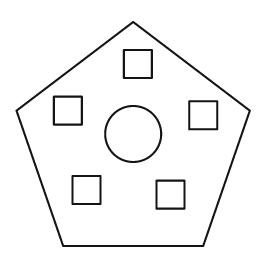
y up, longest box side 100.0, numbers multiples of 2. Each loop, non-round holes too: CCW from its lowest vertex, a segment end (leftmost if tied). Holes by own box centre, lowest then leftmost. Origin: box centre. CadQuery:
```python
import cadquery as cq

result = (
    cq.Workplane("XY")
    .moveTo(-30.0, -48.0)
    .lineTo(30.0, -48.0)
    .lineTo(50.0, 10.0)
    .lineTo(0.0, 48.0)
    .lineTo(-50.0, 10.0)
    .close()
    .moveTo(10.0, -32.0)
    .lineTo(22.0, -32.0)
    .lineTo(22.0, -20.0)
    .lineTo(10.0, -20.0)
    .close()
    .moveTo(-26.0, -30.0)
    .lineTo(-14.0, -30.0)
    .lineTo(-14.0, -18.0)
    .lineTo(-26.0, -18.0)
    .close()
    .moveTo(0.0, 0.0)
    .circle(12.0)
    .moveTo(24.0, 2.0)
    .lineTo(36.0, 2.0)
    .lineTo(36.0, 14.0)
    .lineTo(24.0, 14.0)
    .close()
    .moveTo(-34.0, 4.0)
    .lineTo(-22.0, 4.0)
    .lineTo(-22.0, 16.0)
    .lineTo(-34.0, 16.0)
    .close()
    .moveTo(-4.0, 24.0)
    .lineTo(8.0, 24.0)
    .lineTo(8.0, 36.0)
    .lineTo(-4.0, 36.0)
    .close()
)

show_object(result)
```